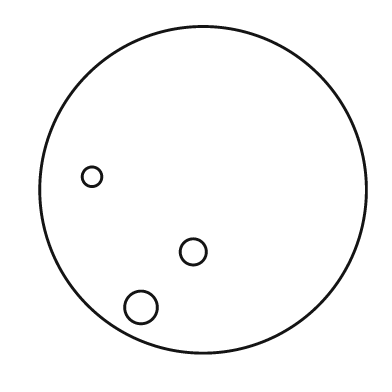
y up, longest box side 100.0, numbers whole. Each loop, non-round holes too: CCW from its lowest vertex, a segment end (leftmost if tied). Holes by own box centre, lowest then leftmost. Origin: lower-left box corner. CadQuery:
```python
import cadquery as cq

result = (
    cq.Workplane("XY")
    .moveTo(50.0, 50.0)
    .circle(50.0)
    .moveTo(31.0, 14.0)
    .circle(5.0)
    .moveTo(47.0, 31.0)
    .circle(4.0)
    .moveTo(16.0, 54.0)
    .circle(3.0)
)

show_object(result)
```